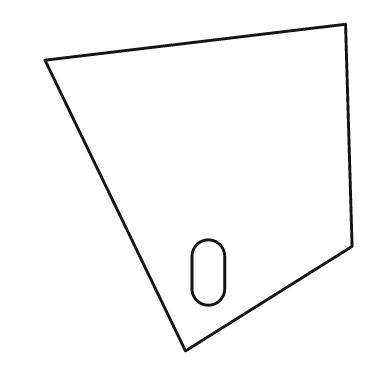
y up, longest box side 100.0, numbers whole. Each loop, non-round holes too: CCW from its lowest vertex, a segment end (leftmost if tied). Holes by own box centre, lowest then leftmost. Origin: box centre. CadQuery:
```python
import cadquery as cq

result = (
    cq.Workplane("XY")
    .moveTo(-4.0, -50.0)
    .lineTo(47.0, -18.0)
    .lineTo(45.0, 50.0)
    .lineTo(-47.0, 39.0)
    .close()
    .moveTo(-2.0, -31.0)
    .threePointArc((3.0, -36.0), (8.0, -31.0))
    .lineTo(8.0, -21.0)
    .threePointArc((3.0, -16.0), (-2.0, -21.0))
    .close()
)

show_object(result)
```